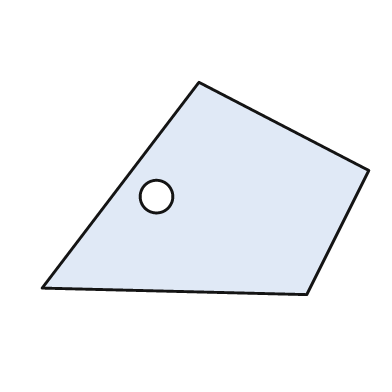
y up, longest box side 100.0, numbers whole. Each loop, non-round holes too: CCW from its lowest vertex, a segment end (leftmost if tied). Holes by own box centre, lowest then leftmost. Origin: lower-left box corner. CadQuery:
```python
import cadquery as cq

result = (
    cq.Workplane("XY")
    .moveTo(81.0, 0.0)
    .lineTo(100.0, 38.0)
    .lineTo(48.0, 65.0)
    .lineTo(0.0, 2.0)
    .close()
    .moveTo(35.0, 30.0)
    .circle(5.0)
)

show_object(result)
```